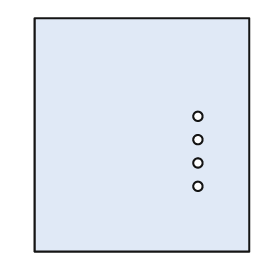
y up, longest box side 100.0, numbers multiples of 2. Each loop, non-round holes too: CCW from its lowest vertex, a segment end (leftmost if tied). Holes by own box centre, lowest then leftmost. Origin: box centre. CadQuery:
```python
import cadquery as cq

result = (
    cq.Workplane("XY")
    .moveTo(-46.0, -50.0)
    .lineTo(46.0, -50.0)
    .lineTo(46.0, 50.0)
    .lineTo(-46.0, 50.0)
    .close()
    .moveTo(24.0, -22.0)
    .circle(2.0)
    .moveTo(24.0, -12.0)
    .circle(2.0)
    .moveTo(24.0, -2.0)
    .circle(2.0)
    .moveTo(24.0, 8.0)
    .circle(2.0)
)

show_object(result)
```